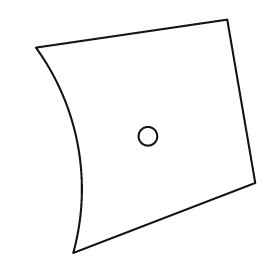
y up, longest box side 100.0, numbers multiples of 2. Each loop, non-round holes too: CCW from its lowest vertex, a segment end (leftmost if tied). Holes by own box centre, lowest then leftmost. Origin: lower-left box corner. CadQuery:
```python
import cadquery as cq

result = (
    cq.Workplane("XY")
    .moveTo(16.0, 0.0)
    .lineTo(94.0, 30.0)
    .lineTo(82.0, 100.0)
    .lineTo(0.0, 88.0)
    .threePointArc((18.0, 46.0), (16.0, 0.0))
    .close()
    .moveTo(48.0, 50.0)
    .circle(4.0)
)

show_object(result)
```